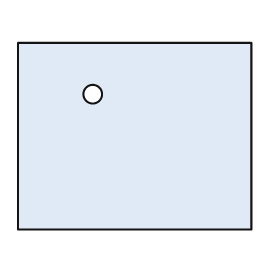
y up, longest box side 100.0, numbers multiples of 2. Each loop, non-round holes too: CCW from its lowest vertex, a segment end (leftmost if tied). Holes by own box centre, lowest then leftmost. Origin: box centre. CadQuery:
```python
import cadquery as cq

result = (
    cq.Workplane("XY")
    .moveTo(-50.0, -40.0)
    .lineTo(50.0, -40.0)
    .lineTo(50.0, 40.0)
    .lineTo(-50.0, 40.0)
    .close()
    .moveTo(-18.0, 18.0)
    .circle(4.0)
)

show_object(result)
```